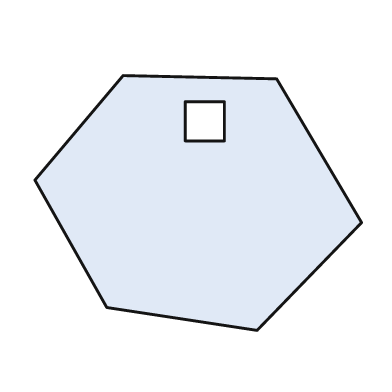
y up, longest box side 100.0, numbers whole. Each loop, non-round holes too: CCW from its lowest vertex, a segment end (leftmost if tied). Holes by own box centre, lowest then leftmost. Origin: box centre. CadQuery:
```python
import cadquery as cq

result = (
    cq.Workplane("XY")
    .moveTo(18.0, -39.0)
    .lineTo(50.0, -6.0)
    .lineTo(24.0, 38.0)
    .lineTo(-23.0, 39.0)
    .lineTo(-50.0, 7.0)
    .lineTo(-28.0, -32.0)
    .close()
    .moveTo(-4.0, 19.0)
    .lineTo(8.0, 19.0)
    .lineTo(8.0, 31.0)
    .lineTo(-4.0, 31.0)
    .close()
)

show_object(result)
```